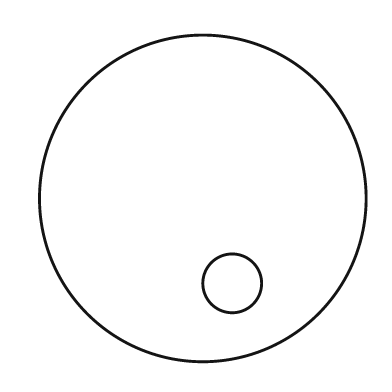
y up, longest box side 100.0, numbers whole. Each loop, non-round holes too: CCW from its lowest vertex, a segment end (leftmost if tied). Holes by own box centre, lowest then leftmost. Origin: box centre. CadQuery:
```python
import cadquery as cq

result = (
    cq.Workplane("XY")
    .moveTo(0.0, 0.0)
    .circle(50.0)
    .moveTo(9.0, -26.0)
    .circle(9.0)
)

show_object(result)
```